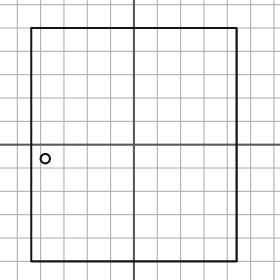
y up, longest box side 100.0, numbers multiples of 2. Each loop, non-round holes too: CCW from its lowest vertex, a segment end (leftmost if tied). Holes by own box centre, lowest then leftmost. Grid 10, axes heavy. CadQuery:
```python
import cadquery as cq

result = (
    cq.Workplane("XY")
    .moveTo(-44.0, -50.0)
    .lineTo(44.0, -50.0)
    .lineTo(44.0, 50.0)
    .lineTo(-44.0, 50.0)
    .close()
    .moveTo(-38.0, -6.0)
    .circle(2.0)
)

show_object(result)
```